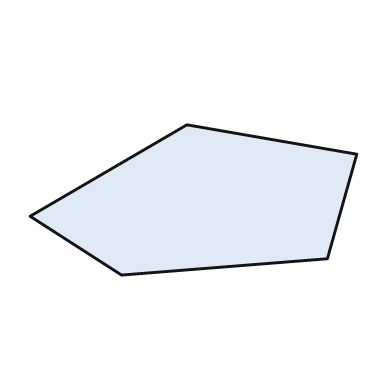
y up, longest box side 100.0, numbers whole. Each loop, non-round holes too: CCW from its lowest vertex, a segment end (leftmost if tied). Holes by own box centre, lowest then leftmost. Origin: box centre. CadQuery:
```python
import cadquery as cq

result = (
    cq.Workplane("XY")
    .moveTo(-22.0, -23.0)
    .lineTo(41.0, -18.0)
    .lineTo(50.0, 14.0)
    .lineTo(-2.0, 23.0)
    .lineTo(-50.0, -5.0)
    .close()
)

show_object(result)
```